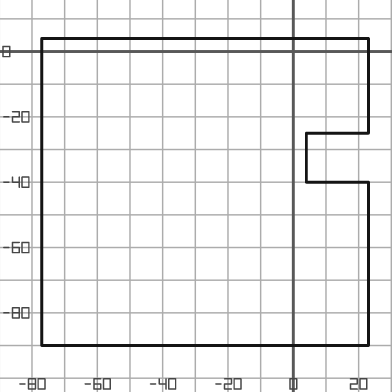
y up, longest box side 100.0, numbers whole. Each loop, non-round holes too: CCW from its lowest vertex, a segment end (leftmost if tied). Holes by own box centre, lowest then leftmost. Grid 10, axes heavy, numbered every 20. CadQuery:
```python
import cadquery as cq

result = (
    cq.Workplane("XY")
    .moveTo(-77.0, -90.0)
    .lineTo(23.0, -90.0)
    .lineTo(23.0, -40.0)
    .lineTo(4.0, -40.0)
    .lineTo(4.0, -25.0)
    .lineTo(23.0, -25.0)
    .lineTo(23.0, 4.0)
    .lineTo(-77.0, 4.0)
    .close()
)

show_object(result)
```